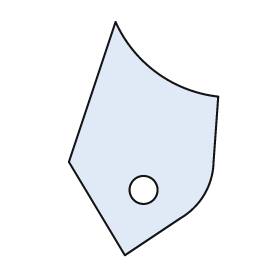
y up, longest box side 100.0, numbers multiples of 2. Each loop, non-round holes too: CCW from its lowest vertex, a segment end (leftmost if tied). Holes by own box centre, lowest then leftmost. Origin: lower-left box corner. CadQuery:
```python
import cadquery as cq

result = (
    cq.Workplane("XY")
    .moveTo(24.0, 0.0)
    .lineTo(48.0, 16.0)
    .threePointArc((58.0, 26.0), (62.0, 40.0))
    .lineTo(64.0, 68.0)
    .threePointArc((38.0, 78.0), (20.0, 100.0))
    .lineTo(0.0, 40.0)
    .close()
    .moveTo(32.0, 28.0)
    .circle(6.0)
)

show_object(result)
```